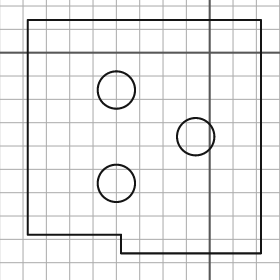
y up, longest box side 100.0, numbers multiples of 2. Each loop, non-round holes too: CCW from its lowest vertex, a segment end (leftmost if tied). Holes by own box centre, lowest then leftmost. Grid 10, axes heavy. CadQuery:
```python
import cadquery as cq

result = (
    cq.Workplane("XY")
    .moveTo(-38.0, -86.0)
    .lineTo(22.0, -86.0)
    .lineTo(22.0, 14.0)
    .lineTo(-78.0, 14.0)
    .lineTo(-78.0, -78.0)
    .lineTo(-38.0, -78.0)
    .close()
    .moveTo(-40.0, -56.0)
    .circle(8.0)
    .moveTo(-6.0, -36.0)
    .circle(8.0)
    .moveTo(-40.0, -16.0)
    .circle(8.0)
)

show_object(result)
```